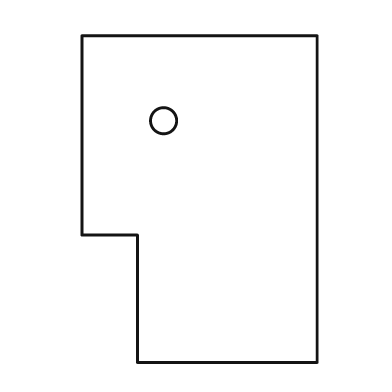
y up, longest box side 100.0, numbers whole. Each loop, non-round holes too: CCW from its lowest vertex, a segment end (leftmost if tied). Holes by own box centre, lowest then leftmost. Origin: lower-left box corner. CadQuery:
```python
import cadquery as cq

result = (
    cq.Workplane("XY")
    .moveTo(17.0, 0.0)
    .lineTo(72.0, 0.0)
    .lineTo(72.0, 100.0)
    .lineTo(0.0, 100.0)
    .lineTo(0.0, 39.0)
    .lineTo(17.0, 39.0)
    .close()
    .moveTo(25.0, 74.0)
    .circle(4.0)
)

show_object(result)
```